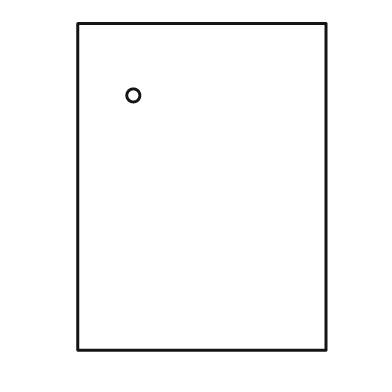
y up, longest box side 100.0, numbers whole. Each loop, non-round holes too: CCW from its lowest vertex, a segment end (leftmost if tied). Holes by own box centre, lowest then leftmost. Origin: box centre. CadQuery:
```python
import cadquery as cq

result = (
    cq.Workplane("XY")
    .moveTo(-38.0, -50.0)
    .lineTo(38.0, -50.0)
    .lineTo(38.0, 50.0)
    .lineTo(-38.0, 50.0)
    .close()
    .moveTo(-21.0, 28.0)
    .circle(2.0)
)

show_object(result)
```